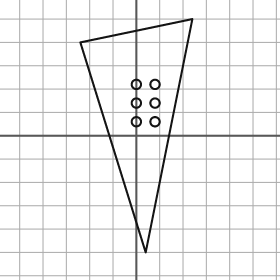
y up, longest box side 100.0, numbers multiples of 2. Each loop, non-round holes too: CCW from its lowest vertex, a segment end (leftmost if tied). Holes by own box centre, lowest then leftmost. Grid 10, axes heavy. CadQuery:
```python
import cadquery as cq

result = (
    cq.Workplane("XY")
    .moveTo(4.0, -50.0)
    .lineTo(24.0, 50.0)
    .lineTo(-24.0, 40.0)
    .close()
    .moveTo(0.0, 6.0)
    .circle(2.0)
    .moveTo(8.0, 6.0)
    .circle(2.0)
    .moveTo(0.0, 14.0)
    .circle(2.0)
    .moveTo(8.0, 14.0)
    .circle(2.0)
    .moveTo(0.0, 22.0)
    .circle(2.0)
    .moveTo(8.0, 22.0)
    .circle(2.0)
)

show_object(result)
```